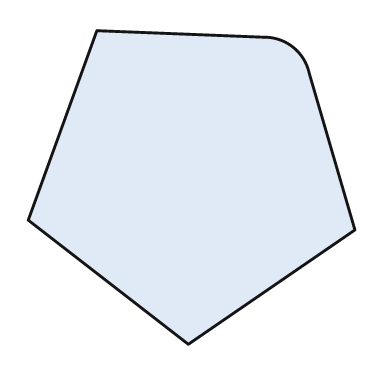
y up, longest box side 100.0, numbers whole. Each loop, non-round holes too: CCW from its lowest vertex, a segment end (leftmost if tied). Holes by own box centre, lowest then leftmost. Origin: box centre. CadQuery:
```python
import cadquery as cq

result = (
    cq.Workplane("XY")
    .moveTo(-1.0, -48.0)
    .lineTo(50.0, -13.0)
    .lineTo(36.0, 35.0)
    .threePointArc((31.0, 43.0), (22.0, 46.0))
    .lineTo(-29.0, 48.0)
    .lineTo(-50.0, -10.0)
    .close()
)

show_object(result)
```